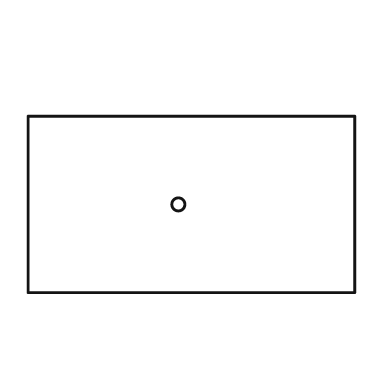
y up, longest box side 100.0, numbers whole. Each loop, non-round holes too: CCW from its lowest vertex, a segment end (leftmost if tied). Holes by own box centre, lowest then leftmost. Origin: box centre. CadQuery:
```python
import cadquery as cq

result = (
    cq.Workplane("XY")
    .moveTo(-50.0, -27.0)
    .lineTo(50.0, -27.0)
    .lineTo(50.0, 27.0)
    .lineTo(-50.0, 27.0)
    .close()
    .moveTo(-4.0, 0.0)
    .circle(2.0)
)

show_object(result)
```